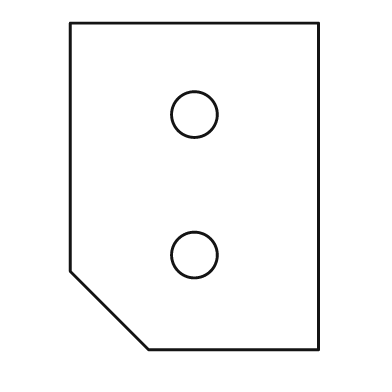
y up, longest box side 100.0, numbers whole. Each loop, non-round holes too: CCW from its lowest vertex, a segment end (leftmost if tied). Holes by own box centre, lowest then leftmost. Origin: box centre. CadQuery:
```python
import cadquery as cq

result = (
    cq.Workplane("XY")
    .moveTo(-14.0, -50.0)
    .lineTo(38.0, -50.0)
    .lineTo(38.0, 50.0)
    .lineTo(-38.0, 50.0)
    .lineTo(-38.0, -26.0)
    .close()
    .moveTo(0.0, -21.0)
    .circle(7.0)
    .moveTo(0.0, 22.0)
    .circle(7.0)
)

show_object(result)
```